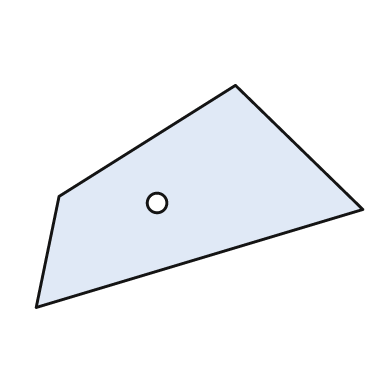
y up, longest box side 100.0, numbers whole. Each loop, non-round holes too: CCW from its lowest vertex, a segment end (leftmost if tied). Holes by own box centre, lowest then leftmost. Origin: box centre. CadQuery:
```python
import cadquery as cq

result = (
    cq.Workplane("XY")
    .moveTo(-50.0, -34.0)
    .lineTo(50.0, -4.0)
    .lineTo(11.0, 34.0)
    .lineTo(-43.0, 0.0)
    .close()
    .moveTo(-13.0, -2.0)
    .circle(3.0)
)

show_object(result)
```